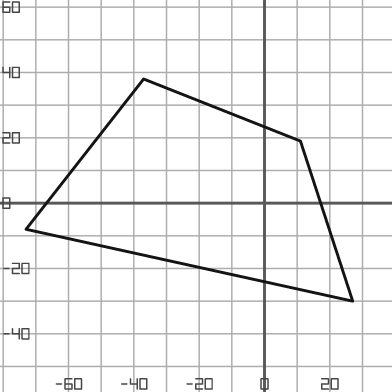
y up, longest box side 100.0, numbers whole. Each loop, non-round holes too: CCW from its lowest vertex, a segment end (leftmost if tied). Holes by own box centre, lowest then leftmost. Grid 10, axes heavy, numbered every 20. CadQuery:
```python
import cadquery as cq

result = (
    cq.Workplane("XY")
    .moveTo(27.0, -30.0)
    .lineTo(11.0, 19.0)
    .lineTo(-37.0, 38.0)
    .lineTo(-73.0, -8.0)
    .close()
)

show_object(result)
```